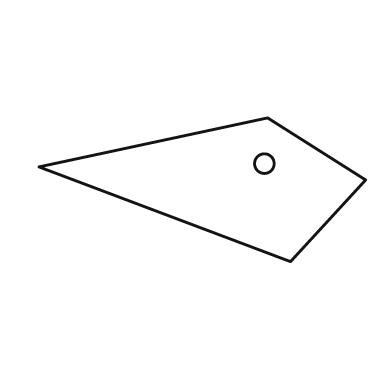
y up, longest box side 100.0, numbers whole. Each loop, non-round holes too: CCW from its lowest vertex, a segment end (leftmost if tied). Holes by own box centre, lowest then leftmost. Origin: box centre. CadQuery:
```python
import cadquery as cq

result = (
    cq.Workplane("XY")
    .moveTo(27.0, -22.0)
    .lineTo(50.0, 3.0)
    .lineTo(20.0, 22.0)
    .lineTo(-50.0, 7.0)
    .close()
    .moveTo(19.0, 8.0)
    .circle(3.0)
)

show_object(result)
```